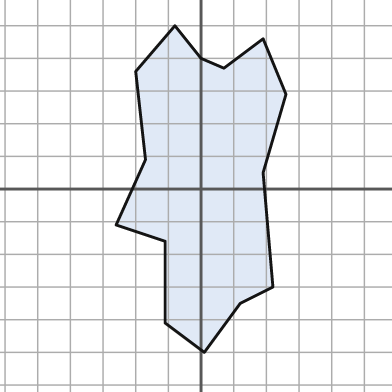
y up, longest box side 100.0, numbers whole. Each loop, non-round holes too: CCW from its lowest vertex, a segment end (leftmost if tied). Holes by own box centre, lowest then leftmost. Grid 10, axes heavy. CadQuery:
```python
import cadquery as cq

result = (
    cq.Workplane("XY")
    .moveTo(1.0, -50.0)
    .lineTo(12.0, -35.0)
    .lineTo(22.0, -30.0)
    .lineTo(19.0, 5.0)
    .lineTo(26.0, 29.0)
    .lineTo(19.0, 46.0)
    .lineTo(7.0, 37.0)
    .lineTo(0.0, 40.0)
    .lineTo(-8.0, 50.0)
    .lineTo(-20.0, 36.0)
    .lineTo(-17.0, 9.0)
    .lineTo(-26.0, -11.0)
    .lineTo(-11.0, -16.0)
    .lineTo(-11.0, -41.0)
    .close()
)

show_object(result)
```